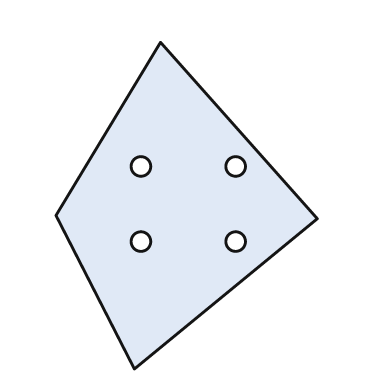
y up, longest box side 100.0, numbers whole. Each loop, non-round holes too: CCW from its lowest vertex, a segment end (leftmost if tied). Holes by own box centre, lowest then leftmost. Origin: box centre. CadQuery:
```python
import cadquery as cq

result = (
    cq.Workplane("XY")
    .moveTo(-16.0, -50.0)
    .lineTo(40.0, -4.0)
    .lineTo(-8.0, 50.0)
    .lineTo(-40.0, -3.0)
    .close()
    .moveTo(-14.0, -11.0)
    .circle(3.0)
    .moveTo(15.0, -11.0)
    .circle(3.0)
    .moveTo(-14.0, 12.0)
    .circle(3.0)
    .moveTo(15.0, 12.0)
    .circle(3.0)
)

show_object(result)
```